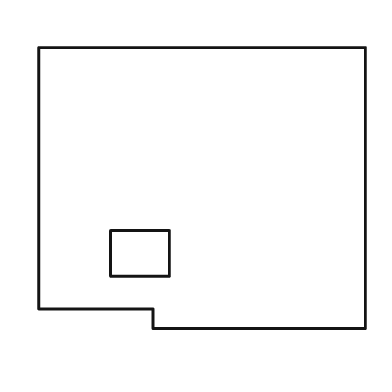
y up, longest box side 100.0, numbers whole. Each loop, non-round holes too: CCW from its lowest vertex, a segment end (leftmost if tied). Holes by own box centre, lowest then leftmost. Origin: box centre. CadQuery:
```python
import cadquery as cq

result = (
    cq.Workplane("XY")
    .moveTo(-15.0, -43.0)
    .lineTo(50.0, -43.0)
    .lineTo(50.0, 43.0)
    .lineTo(-50.0, 43.0)
    .lineTo(-50.0, -37.0)
    .lineTo(-15.0, -37.0)
    .close()
    .moveTo(-28.0, -27.0)
    .lineTo(-10.0, -27.0)
    .lineTo(-10.0, -13.0)
    .lineTo(-28.0, -13.0)
    .close()
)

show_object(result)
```